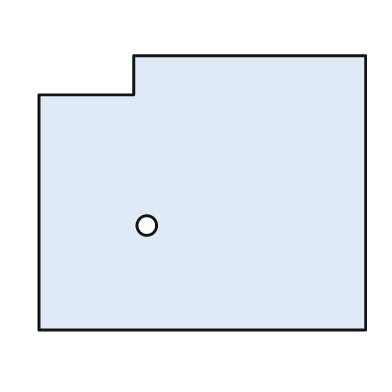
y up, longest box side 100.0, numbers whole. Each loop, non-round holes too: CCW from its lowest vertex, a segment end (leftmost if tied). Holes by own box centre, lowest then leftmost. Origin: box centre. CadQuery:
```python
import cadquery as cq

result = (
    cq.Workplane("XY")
    .moveTo(-50.0, -42.0)
    .lineTo(50.0, -42.0)
    .lineTo(50.0, 42.0)
    .lineTo(-21.0, 42.0)
    .lineTo(-21.0, 30.0)
    .lineTo(-50.0, 30.0)
    .close()
    .moveTo(-17.0, -10.0)
    .circle(3.0)
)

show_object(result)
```